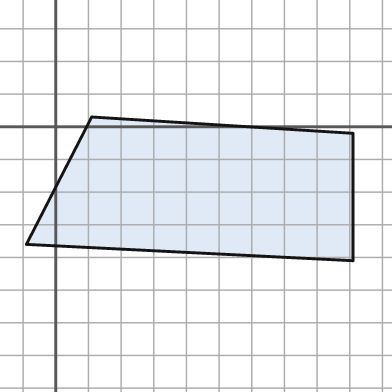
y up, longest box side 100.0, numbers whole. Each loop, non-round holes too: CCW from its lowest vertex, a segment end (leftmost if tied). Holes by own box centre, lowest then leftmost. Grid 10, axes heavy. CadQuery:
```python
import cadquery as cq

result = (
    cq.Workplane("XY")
    .moveTo(91.0, -41.0)
    .lineTo(91.0, -2.0)
    .lineTo(11.0, 3.0)
    .lineTo(-9.0, -36.0)
    .close()
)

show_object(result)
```